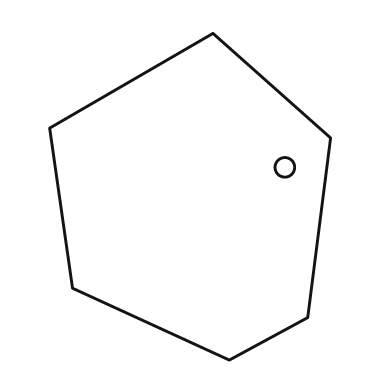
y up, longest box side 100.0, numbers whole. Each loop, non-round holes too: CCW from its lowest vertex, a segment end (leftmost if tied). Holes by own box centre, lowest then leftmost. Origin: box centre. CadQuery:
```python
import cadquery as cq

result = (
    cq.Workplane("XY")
    .moveTo(12.0, -50.0)
    .lineTo(36.0, -37.0)
    .lineTo(43.0, 18.0)
    .lineTo(7.0, 50.0)
    .lineTo(-43.0, 21.0)
    .lineTo(-36.0, -28.0)
    .close()
    .moveTo(29.0, 9.0)
    .circle(3.0)
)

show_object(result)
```